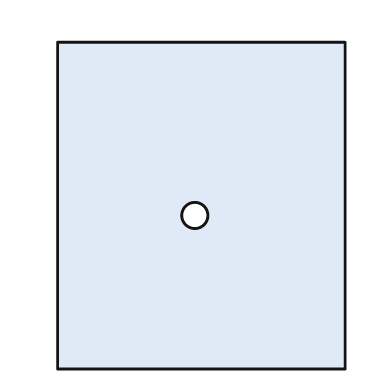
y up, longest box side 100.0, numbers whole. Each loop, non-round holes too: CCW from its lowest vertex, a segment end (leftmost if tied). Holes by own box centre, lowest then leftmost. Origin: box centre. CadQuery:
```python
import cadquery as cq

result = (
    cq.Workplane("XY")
    .moveTo(-44.0, -50.0)
    .lineTo(44.0, -50.0)
    .lineTo(44.0, 50.0)
    .lineTo(-44.0, 50.0)
    .close()
    .moveTo(-2.0, -3.0)
    .circle(4.0)
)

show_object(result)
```